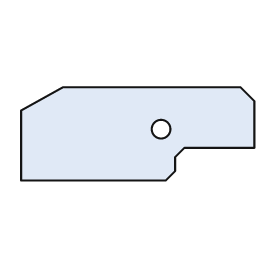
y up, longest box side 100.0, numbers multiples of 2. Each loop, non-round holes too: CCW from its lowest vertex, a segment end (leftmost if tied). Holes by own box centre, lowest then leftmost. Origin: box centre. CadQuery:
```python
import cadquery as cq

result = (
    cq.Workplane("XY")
    .moveTo(-50.0, -20.0)
    .lineTo(12.0, -20.0)
    .lineTo(16.0, -16.0)
    .lineTo(16.0, -10.0)
    .lineTo(20.0, -6.0)
    .lineTo(50.0, -6.0)
    .lineTo(50.0, 14.0)
    .lineTo(44.0, 20.0)
    .lineTo(-32.0, 20.0)
    .lineTo(-50.0, 10.0)
    .close()
    .moveTo(10.0, 2.0)
    .circle(4.0)
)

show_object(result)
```